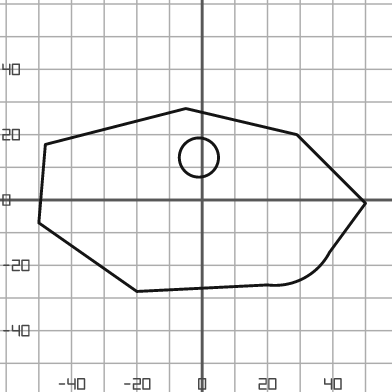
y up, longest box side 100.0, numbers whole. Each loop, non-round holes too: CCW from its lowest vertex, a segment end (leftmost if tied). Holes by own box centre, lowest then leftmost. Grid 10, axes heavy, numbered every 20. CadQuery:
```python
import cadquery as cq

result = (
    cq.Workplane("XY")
    .moveTo(-20.0, -28.0)
    .lineTo(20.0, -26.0)
    .threePointArc((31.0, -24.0), (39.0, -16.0))
    .lineTo(50.0, -1.0)
    .lineTo(29.0, 20.0)
    .lineTo(-5.0, 28.0)
    .lineTo(-48.0, 17.0)
    .lineTo(-50.0, -7.0)
    .close()
    .moveTo(-1.0, 13.0)
    .circle(6.0)
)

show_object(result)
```